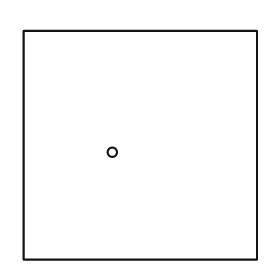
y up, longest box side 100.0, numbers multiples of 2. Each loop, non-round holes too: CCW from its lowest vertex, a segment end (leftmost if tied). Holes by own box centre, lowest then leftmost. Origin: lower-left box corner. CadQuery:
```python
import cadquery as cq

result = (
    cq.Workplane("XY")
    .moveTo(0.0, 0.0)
    .lineTo(100.0, 0.0)
    .lineTo(100.0, 98.0)
    .lineTo(0.0, 98.0)
    .close()
    .moveTo(38.0, 46.0)
    .circle(2.0)
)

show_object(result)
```